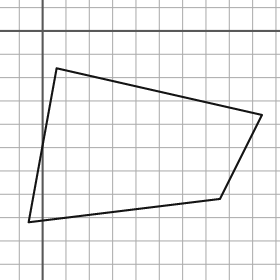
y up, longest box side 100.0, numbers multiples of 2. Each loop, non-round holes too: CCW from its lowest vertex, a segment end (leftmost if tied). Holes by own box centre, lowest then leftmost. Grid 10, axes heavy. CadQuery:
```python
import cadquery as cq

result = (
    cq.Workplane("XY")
    .moveTo(-6.0, -82.0)
    .lineTo(76.0, -72.0)
    .lineTo(94.0, -36.0)
    .lineTo(6.0, -16.0)
    .close()
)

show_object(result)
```